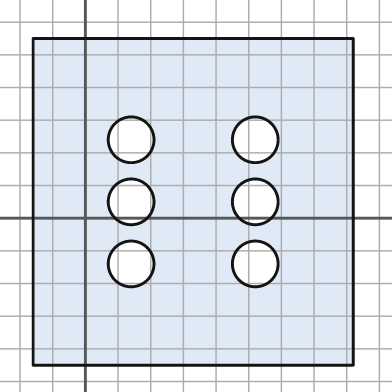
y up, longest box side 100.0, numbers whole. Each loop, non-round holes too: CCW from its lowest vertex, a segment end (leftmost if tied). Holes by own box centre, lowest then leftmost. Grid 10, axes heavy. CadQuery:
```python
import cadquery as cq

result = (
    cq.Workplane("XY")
    .moveTo(-16.0, -45.0)
    .lineTo(82.0, -45.0)
    .lineTo(82.0, 55.0)
    .lineTo(-16.0, 55.0)
    .close()
    .moveTo(14.0, -14.0)
    .circle(7.0)
    .moveTo(52.0, -14.0)
    .circle(7.0)
    .moveTo(14.0, 5.0)
    .circle(7.0)
    .moveTo(52.0, 5.0)
    .circle(7.0)
    .moveTo(14.0, 24.0)
    .circle(7.0)
    .moveTo(52.0, 24.0)
    .circle(7.0)
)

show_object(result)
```